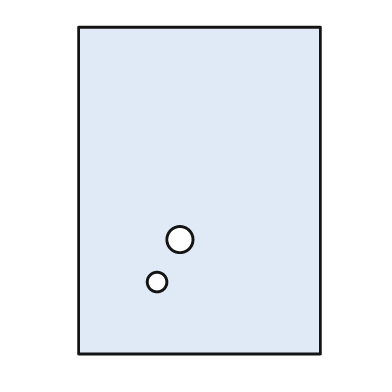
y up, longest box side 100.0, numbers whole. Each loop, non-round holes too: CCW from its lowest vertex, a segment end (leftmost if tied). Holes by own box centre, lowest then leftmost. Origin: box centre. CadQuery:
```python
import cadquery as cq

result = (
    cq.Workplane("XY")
    .moveTo(-37.0, -50.0)
    .lineTo(37.0, -50.0)
    .lineTo(37.0, 50.0)
    .lineTo(-37.0, 50.0)
    .close()
    .moveTo(-13.0, -28.0)
    .circle(3.0)
    .moveTo(-6.0, -15.0)
    .circle(4.0)
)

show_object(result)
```